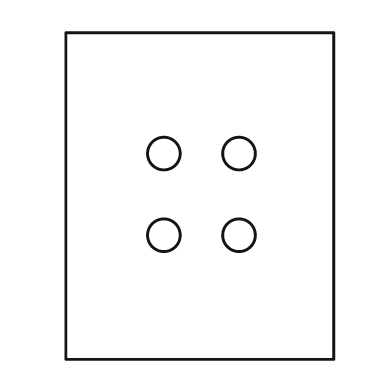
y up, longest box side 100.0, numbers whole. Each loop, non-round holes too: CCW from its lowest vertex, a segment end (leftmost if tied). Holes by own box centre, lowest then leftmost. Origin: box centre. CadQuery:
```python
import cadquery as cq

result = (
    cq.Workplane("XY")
    .moveTo(-41.0, -50.0)
    .lineTo(41.0, -50.0)
    .lineTo(41.0, 50.0)
    .lineTo(-41.0, 50.0)
    .close()
    .moveTo(-11.0, -12.0)
    .circle(5.0)
    .moveTo(12.0, -12.0)
    .circle(5.0)
    .moveTo(-11.0, 13.0)
    .circle(5.0)
    .moveTo(12.0, 13.0)
    .circle(5.0)
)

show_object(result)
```